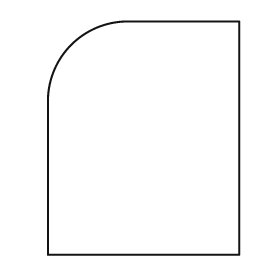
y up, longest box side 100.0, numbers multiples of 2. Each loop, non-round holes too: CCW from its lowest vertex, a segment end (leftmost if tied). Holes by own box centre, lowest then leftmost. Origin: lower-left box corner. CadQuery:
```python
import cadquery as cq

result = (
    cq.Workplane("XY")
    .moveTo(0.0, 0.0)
    .lineTo(82.0, 0.0)
    .lineTo(82.0, 100.0)
    .lineTo(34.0, 100.0)
    .threePointArc((10.0, 90.0), (0.0, 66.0))
    .close()
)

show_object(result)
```